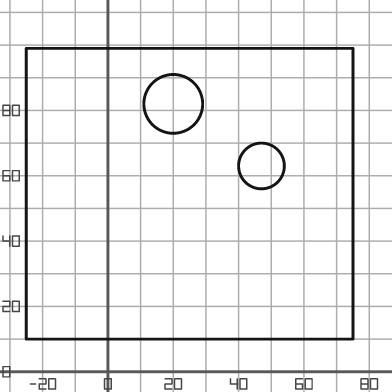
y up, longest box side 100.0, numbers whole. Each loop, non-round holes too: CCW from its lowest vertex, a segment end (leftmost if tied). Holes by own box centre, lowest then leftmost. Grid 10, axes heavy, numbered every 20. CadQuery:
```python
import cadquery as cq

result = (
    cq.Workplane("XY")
    .moveTo(-25.0, 10.0)
    .lineTo(75.0, 10.0)
    .lineTo(75.0, 99.0)
    .lineTo(-25.0, 99.0)
    .close()
    .moveTo(47.0, 63.0)
    .circle(7.0)
    .moveTo(20.0, 82.0)
    .circle(9.0)
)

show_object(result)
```